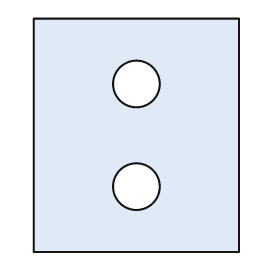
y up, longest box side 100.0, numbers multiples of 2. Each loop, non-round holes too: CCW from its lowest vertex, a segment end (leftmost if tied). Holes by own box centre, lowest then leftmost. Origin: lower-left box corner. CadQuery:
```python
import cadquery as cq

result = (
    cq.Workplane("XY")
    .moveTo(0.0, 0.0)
    .lineTo(88.0, 0.0)
    .lineTo(88.0, 100.0)
    .lineTo(0.0, 100.0)
    .close()
    .moveTo(44.0, 28.0)
    .circle(10.0)
    .moveTo(44.0, 72.0)
    .circle(10.0)
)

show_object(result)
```